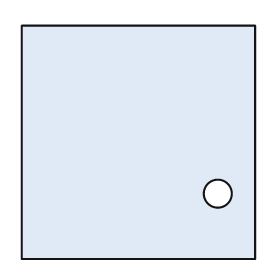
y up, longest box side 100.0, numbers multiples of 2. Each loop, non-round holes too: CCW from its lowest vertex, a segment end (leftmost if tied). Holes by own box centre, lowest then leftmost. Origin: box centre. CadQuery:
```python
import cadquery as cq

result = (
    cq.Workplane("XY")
    .moveTo(-50.0, -50.0)
    .lineTo(50.0, -50.0)
    .lineTo(50.0, 50.0)
    .lineTo(-50.0, 50.0)
    .close()
    .moveTo(34.0, -22.0)
    .circle(6.0)
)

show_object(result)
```